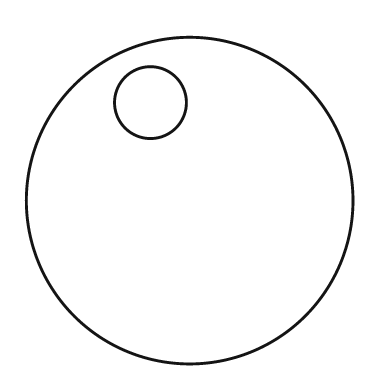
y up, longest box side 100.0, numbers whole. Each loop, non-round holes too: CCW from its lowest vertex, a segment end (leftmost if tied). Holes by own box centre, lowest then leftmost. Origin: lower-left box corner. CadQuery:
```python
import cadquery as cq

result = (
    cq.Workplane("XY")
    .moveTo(50.0, 50.0)
    .circle(50.0)
    .moveTo(38.0, 80.0)
    .circle(11.0)
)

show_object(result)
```